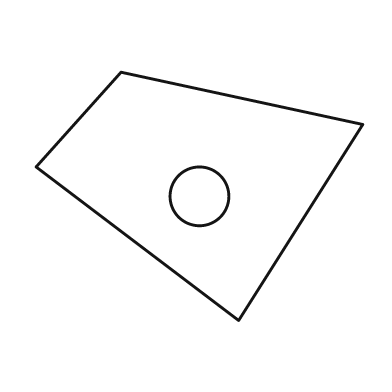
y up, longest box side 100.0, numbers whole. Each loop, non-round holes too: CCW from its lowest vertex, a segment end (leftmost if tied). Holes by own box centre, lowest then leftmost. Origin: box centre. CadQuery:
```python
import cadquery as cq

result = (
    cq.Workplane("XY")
    .moveTo(12.0, -38.0)
    .lineTo(50.0, 22.0)
    .lineTo(-24.0, 38.0)
    .lineTo(-50.0, 9.0)
    .close()
    .moveTo(0.0, 0.0)
    .circle(9.0)
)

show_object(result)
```